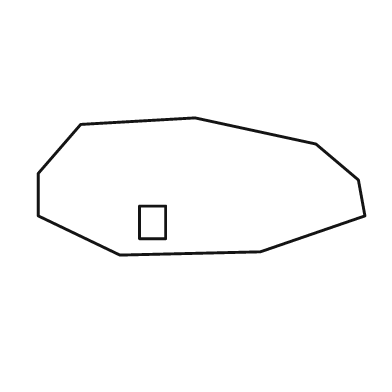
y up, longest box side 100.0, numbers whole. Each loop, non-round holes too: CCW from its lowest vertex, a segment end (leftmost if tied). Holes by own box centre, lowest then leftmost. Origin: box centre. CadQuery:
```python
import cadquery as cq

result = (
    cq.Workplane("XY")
    .moveTo(-25.0, -21.0)
    .lineTo(18.0, -20.0)
    .lineTo(50.0, -9.0)
    .lineTo(48.0, 2.0)
    .lineTo(35.0, 13.0)
    .lineTo(-2.0, 21.0)
    .lineTo(-37.0, 19.0)
    .lineTo(-50.0, 4.0)
    .lineTo(-50.0, -9.0)
    .close()
    .moveTo(-19.0, -16.0)
    .lineTo(-11.0, -16.0)
    .lineTo(-11.0, -6.0)
    .lineTo(-19.0, -6.0)
    .close()
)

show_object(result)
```